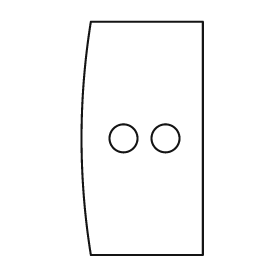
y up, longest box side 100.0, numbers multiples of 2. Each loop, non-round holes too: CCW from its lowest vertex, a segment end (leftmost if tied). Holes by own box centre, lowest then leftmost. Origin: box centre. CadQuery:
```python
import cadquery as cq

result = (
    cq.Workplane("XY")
    .moveTo(-22.0, -50.0)
    .lineTo(26.0, -50.0)
    .lineTo(26.0, 50.0)
    .lineTo(-22.0, 50.0)
    .threePointArc((-26.0, 0.0), (-22.0, -50.0))
    .close()
    .moveTo(-8.0, 0.0)
    .circle(6.0)
    .moveTo(10.0, 0.0)
    .circle(6.0)
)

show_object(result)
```